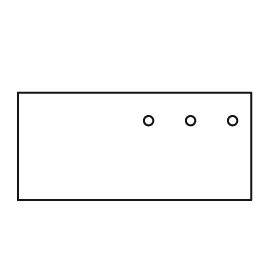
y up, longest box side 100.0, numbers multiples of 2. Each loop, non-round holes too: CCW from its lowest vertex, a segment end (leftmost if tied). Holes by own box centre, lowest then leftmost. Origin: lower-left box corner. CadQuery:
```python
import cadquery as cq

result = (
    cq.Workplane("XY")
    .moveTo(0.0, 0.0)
    .lineTo(100.0, 0.0)
    .lineTo(100.0, 46.0)
    .lineTo(0.0, 46.0)
    .close()
    .moveTo(56.0, 34.0)
    .circle(2.0)
    .moveTo(74.0, 34.0)
    .circle(2.0)
    .moveTo(92.0, 34.0)
    .circle(2.0)
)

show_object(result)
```